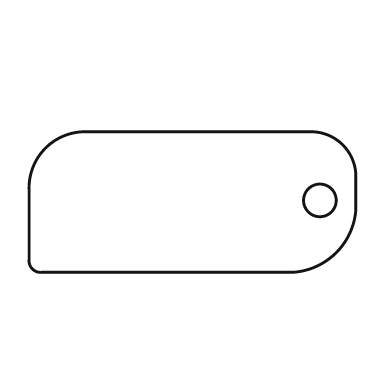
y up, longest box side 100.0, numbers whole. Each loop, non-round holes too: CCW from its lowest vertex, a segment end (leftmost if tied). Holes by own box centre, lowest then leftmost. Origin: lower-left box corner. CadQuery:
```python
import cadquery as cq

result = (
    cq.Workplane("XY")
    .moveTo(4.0, 0.0)
    .lineTo(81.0, 0.0)
    .threePointArc((94.0, 6.0), (100.0, 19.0))
    .lineTo(100.0, 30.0)
    .threePointArc((96.0, 39.0), (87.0, 43.0))
    .lineTo(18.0, 43.0)
    .threePointArc((5.0, 38.0), (0.0, 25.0))
    .lineTo(0.0, 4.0)
    .threePointArc((1.0, 1.0), (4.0, 0.0))
    .close()
    .moveTo(89.0, 22.0)
    .circle(5.0)
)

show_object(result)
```